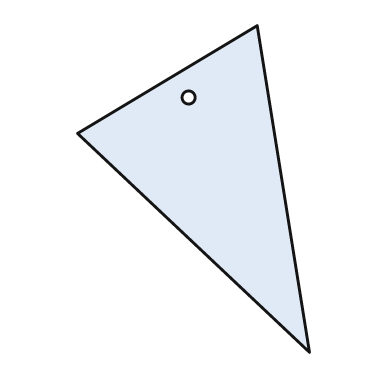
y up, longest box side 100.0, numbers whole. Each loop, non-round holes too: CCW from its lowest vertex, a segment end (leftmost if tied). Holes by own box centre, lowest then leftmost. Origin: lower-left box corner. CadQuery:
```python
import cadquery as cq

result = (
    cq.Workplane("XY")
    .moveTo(71.0, 0.0)
    .lineTo(55.0, 100.0)
    .lineTo(0.0, 67.0)
    .close()
    .moveTo(34.0, 78.0)
    .circle(2.0)
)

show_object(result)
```